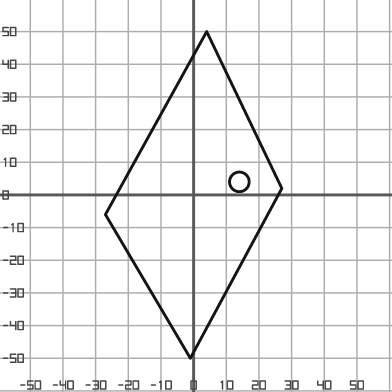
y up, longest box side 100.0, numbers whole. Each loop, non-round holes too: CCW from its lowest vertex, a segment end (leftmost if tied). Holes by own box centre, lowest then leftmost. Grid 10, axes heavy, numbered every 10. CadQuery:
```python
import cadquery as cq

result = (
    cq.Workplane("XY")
    .moveTo(-1.0, -50.0)
    .lineTo(27.0, 2.0)
    .lineTo(4.0, 50.0)
    .lineTo(-27.0, -6.0)
    .close()
    .moveTo(14.0, 4.0)
    .circle(3.0)
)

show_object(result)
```